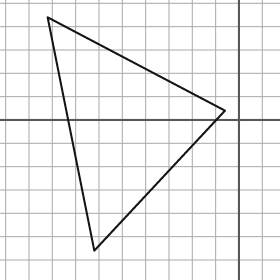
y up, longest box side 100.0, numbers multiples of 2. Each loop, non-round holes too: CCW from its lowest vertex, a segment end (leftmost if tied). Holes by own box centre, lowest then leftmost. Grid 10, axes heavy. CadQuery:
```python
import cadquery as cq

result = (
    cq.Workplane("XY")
    .moveTo(-62.0, -56.0)
    .lineTo(-6.0, 4.0)
    .lineTo(-82.0, 44.0)
    .close()
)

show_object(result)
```